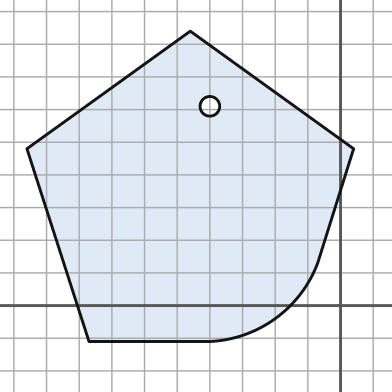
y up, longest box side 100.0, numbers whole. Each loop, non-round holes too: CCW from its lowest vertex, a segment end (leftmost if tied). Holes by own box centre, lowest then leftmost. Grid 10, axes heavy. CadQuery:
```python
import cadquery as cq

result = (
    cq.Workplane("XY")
    .moveTo(-77.0, -11.0)
    .lineTo(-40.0, -11.0)
    .threePointArc((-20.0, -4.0), (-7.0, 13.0))
    .lineTo(4.0, 48.0)
    .lineTo(-46.0, 84.0)
    .lineTo(-96.0, 48.0)
    .close()
    .moveTo(-40.0, 61.0)
    .circle(3.0)
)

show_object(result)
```